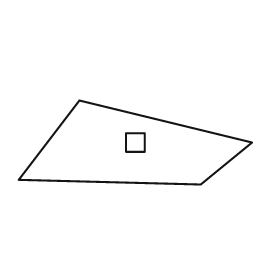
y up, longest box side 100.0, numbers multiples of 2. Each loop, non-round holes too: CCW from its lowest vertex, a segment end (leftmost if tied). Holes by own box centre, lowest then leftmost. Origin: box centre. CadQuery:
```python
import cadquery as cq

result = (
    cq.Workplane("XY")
    .moveTo(28.0, -18.0)
    .lineTo(50.0, 0.0)
    .lineTo(-24.0, 18.0)
    .lineTo(-50.0, -16.0)
    .close()
    .moveTo(-4.0, -4.0)
    .lineTo(4.0, -4.0)
    .lineTo(4.0, 4.0)
    .lineTo(-4.0, 4.0)
    .close()
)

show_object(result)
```